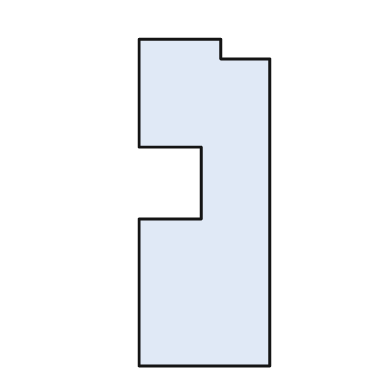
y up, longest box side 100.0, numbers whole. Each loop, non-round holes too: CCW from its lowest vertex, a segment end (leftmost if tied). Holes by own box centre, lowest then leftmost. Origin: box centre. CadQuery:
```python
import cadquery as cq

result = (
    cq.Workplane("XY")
    .moveTo(-20.0, -50.0)
    .lineTo(20.0, -50.0)
    .lineTo(20.0, 44.0)
    .lineTo(5.0, 44.0)
    .lineTo(5.0, 50.0)
    .lineTo(-20.0, 50.0)
    .lineTo(-20.0, 17.0)
    .lineTo(-1.0, 17.0)
    .lineTo(-1.0, -5.0)
    .lineTo(-20.0, -5.0)
    .close()
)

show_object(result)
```